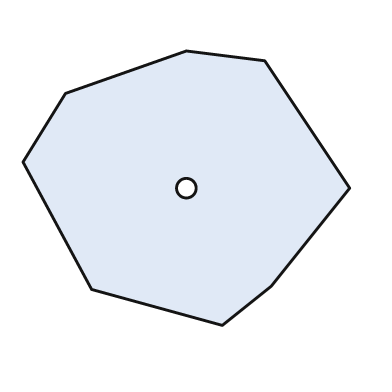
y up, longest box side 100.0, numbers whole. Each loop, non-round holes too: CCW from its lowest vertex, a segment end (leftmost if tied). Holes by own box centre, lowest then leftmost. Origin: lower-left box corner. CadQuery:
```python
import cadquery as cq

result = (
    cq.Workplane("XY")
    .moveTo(61.0, 0.0)
    .lineTo(76.0, 12.0)
    .lineTo(100.0, 42.0)
    .lineTo(74.0, 81.0)
    .lineTo(50.0, 84.0)
    .lineTo(13.0, 71.0)
    .lineTo(0.0, 50.0)
    .lineTo(21.0, 11.0)
    .close()
    .moveTo(50.0, 42.0)
    .circle(3.0)
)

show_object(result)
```